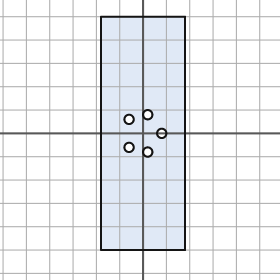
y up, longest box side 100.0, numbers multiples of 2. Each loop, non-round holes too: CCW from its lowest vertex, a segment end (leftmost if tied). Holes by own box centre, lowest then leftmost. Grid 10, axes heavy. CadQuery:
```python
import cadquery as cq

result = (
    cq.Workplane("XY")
    .moveTo(-18.0, -50.0)
    .lineTo(18.0, -50.0)
    .lineTo(18.0, 50.0)
    .lineTo(-18.0, 50.0)
    .close()
    .moveTo(2.0, -8.0)
    .circle(2.0)
    .moveTo(-6.0, -6.0)
    .circle(2.0)
    .moveTo(8.0, 0.0)
    .circle(2.0)
    .moveTo(-6.0, 6.0)
    .circle(2.0)
    .moveTo(2.0, 8.0)
    .circle(2.0)
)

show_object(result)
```